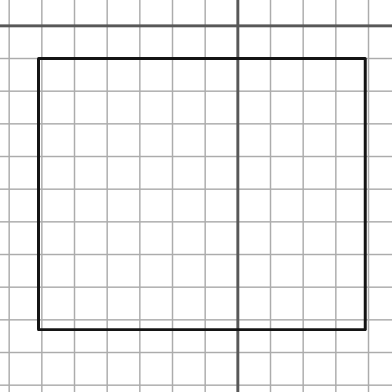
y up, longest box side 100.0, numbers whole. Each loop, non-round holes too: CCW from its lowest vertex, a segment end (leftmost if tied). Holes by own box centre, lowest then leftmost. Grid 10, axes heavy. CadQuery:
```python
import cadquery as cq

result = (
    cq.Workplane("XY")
    .moveTo(-61.0, -93.0)
    .lineTo(39.0, -93.0)
    .lineTo(39.0, -10.0)
    .lineTo(-61.0, -10.0)
    .close()
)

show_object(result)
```